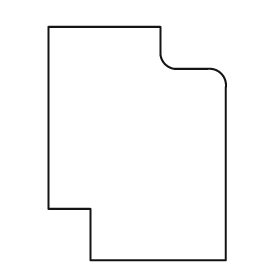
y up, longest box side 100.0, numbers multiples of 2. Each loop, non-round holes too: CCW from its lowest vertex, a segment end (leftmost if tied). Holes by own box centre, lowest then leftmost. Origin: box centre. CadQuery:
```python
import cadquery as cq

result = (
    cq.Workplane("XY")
    .moveTo(-20.0, -50.0)
    .lineTo(38.0, -50.0)
    .lineTo(38.0, 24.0)
    .threePointArc((36.0, 30.0), (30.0, 32.0))
    .lineTo(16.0, 32.0)
    .threePointArc((12.0, 34.0), (10.0, 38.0))
    .lineTo(10.0, 50.0)
    .lineTo(-38.0, 50.0)
    .lineTo(-38.0, -28.0)
    .lineTo(-20.0, -28.0)
    .close()
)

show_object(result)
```